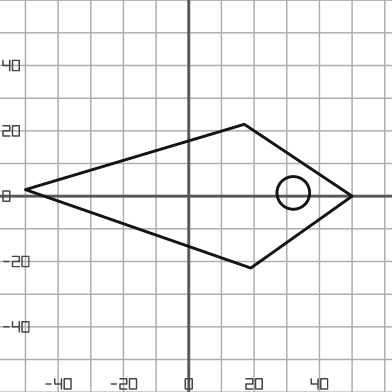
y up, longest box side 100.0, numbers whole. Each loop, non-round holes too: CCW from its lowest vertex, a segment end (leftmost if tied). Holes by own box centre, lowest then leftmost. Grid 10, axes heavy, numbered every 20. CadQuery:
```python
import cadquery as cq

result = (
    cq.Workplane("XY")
    .moveTo(19.0, -22.0)
    .lineTo(50.0, 0.0)
    .lineTo(17.0, 22.0)
    .lineTo(-50.0, 2.0)
    .close()
    .moveTo(32.0, 1.0)
    .circle(5.0)
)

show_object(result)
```